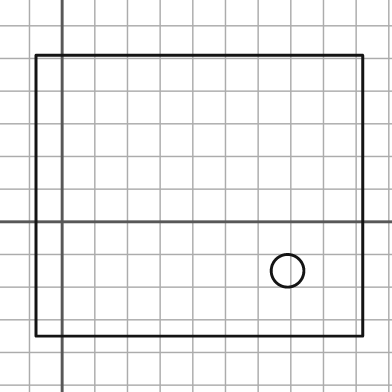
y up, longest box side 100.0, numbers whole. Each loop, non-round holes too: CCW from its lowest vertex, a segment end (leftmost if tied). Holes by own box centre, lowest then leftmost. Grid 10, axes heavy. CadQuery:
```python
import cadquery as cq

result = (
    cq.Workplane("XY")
    .moveTo(-8.0, -35.0)
    .lineTo(92.0, -35.0)
    .lineTo(92.0, 51.0)
    .lineTo(-8.0, 51.0)
    .close()
    .moveTo(69.0, -15.0)
    .circle(5.0)
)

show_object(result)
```